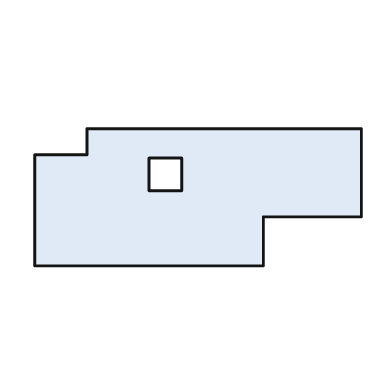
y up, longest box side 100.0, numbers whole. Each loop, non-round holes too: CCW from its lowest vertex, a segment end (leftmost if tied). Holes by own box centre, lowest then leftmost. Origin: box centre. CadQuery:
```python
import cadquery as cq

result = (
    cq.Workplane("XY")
    .moveTo(-50.0, -21.0)
    .lineTo(20.0, -21.0)
    .lineTo(20.0, -6.0)
    .lineTo(50.0, -6.0)
    .lineTo(50.0, 21.0)
    .lineTo(-34.0, 21.0)
    .lineTo(-34.0, 13.0)
    .lineTo(-50.0, 13.0)
    .close()
    .moveTo(-15.0, 2.0)
    .lineTo(-5.0, 2.0)
    .lineTo(-5.0, 12.0)
    .lineTo(-15.0, 12.0)
    .close()
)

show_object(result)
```